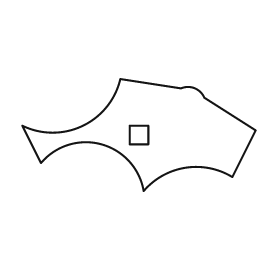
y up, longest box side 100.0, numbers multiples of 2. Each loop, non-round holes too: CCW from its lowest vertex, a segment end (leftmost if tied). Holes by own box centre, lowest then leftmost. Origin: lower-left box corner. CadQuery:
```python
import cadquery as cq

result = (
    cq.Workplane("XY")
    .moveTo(52.0, 0.0)
    .threePointArc((70.0, 10.0), (90.0, 6.0))
    .lineTo(100.0, 26.0)
    .lineTo(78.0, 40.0)
    .threePointArc((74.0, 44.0), (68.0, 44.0))
    .lineTo(42.0, 48.0)
    .threePointArc((26.0, 28.0), (0.0, 28.0))
    .lineTo(8.0, 12.0)
    .threePointArc((34.0, 20.0), (52.0, 0.0))
    .close()
    .moveTo(46.0, 20.0)
    .lineTo(54.0, 20.0)
    .lineTo(54.0, 28.0)
    .lineTo(46.0, 28.0)
    .close()
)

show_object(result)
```